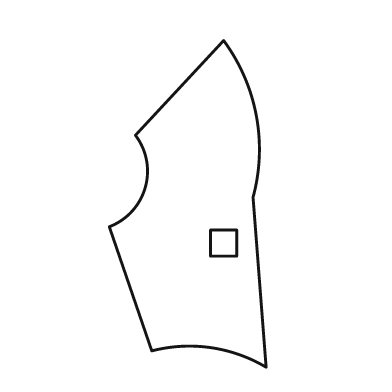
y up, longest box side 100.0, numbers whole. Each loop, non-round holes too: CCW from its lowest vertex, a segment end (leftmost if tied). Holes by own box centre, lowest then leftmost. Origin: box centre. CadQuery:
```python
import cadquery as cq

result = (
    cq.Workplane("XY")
    .moveTo(24.0, -50.0)
    .lineTo(20.0, 2.0)
    .threePointArc((21.0, 27.0), (11.0, 50.0))
    .lineTo(-16.0, 21.0)
    .threePointArc((-13.0, 5.0), (-24.0, -7.0))
    .lineTo(-11.0, -45.0)
    .threePointArc((7.0, -44.0), (24.0, -50.0))
    .close()
    .moveTo(7.0, -16.0)
    .lineTo(15.0, -16.0)
    .lineTo(15.0, -8.0)
    .lineTo(7.0, -8.0)
    .close()
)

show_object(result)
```